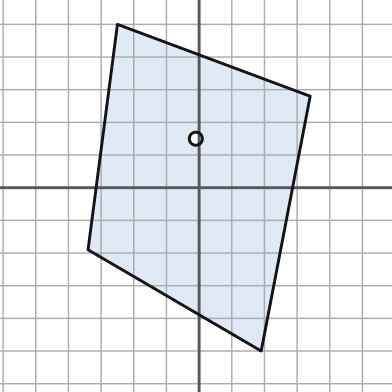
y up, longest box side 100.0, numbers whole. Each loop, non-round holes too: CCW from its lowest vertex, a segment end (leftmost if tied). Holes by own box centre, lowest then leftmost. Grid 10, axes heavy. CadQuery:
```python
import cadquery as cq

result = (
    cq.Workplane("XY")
    .moveTo(19.0, -50.0)
    .lineTo(34.0, 28.0)
    .lineTo(-25.0, 50.0)
    .lineTo(-34.0, -19.0)
    .close()
    .moveTo(-1.0, 15.0)
    .circle(2.0)
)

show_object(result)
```